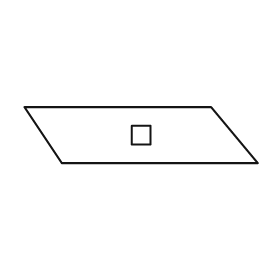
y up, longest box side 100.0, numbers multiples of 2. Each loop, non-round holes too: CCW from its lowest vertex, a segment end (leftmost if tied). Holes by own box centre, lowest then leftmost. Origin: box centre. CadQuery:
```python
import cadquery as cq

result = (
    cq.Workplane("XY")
    .moveTo(-34.0, -12.0)
    .lineTo(50.0, -12.0)
    .lineTo(30.0, 12.0)
    .lineTo(-50.0, 12.0)
    .close()
    .moveTo(-4.0, -4.0)
    .lineTo(4.0, -4.0)
    .lineTo(4.0, 4.0)
    .lineTo(-4.0, 4.0)
    .close()
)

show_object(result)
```